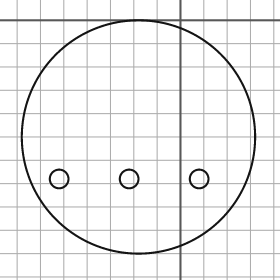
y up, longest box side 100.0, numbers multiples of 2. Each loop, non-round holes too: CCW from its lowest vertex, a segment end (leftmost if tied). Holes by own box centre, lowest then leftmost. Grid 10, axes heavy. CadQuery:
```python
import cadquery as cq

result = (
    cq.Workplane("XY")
    .moveTo(-18.0, -50.0)
    .circle(50.0)
    .moveTo(-52.0, -68.0)
    .circle(4.0)
    .moveTo(-22.0, -68.0)
    .circle(4.0)
    .moveTo(8.0, -68.0)
    .circle(4.0)
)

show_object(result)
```